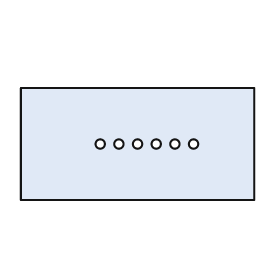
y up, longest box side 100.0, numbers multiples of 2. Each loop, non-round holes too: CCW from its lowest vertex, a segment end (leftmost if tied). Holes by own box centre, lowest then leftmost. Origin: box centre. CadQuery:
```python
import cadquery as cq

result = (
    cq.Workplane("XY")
    .moveTo(-50.0, -24.0)
    .lineTo(50.0, -24.0)
    .lineTo(50.0, 24.0)
    .lineTo(-50.0, 24.0)
    .close()
    .moveTo(-16.0, 0.0)
    .circle(2.0)
    .moveTo(-8.0, 0.0)
    .circle(2.0)
    .moveTo(0.0, 0.0)
    .circle(2.0)
    .moveTo(8.0, 0.0)
    .circle(2.0)
    .moveTo(16.0, 0.0)
    .circle(2.0)
    .moveTo(24.0, 0.0)
    .circle(2.0)
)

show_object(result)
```